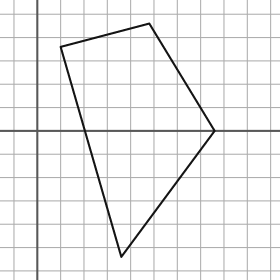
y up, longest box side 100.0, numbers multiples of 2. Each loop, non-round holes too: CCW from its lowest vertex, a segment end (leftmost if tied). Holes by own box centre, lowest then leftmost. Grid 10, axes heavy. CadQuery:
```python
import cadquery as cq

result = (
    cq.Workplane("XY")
    .moveTo(36.0, -54.0)
    .lineTo(76.0, 0.0)
    .lineTo(48.0, 46.0)
    .lineTo(10.0, 36.0)
    .close()
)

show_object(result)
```